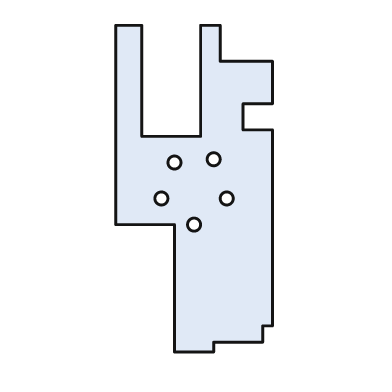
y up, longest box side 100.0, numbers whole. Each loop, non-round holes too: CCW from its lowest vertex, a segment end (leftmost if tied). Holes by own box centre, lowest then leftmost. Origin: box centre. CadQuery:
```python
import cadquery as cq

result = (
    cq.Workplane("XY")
    .moveTo(-6.0, -50.0)
    .lineTo(6.0, -50.0)
    .lineTo(6.0, -47.0)
    .lineTo(21.0, -47.0)
    .lineTo(21.0, -42.0)
    .lineTo(24.0, -42.0)
    .lineTo(24.0, 18.0)
    .lineTo(15.0, 18.0)
    .lineTo(15.0, 26.0)
    .lineTo(24.0, 26.0)
    .lineTo(24.0, 39.0)
    .lineTo(8.0, 39.0)
    .lineTo(8.0, 50.0)
    .lineTo(2.0, 50.0)
    .lineTo(2.0, 16.0)
    .lineTo(-16.0, 16.0)
    .lineTo(-16.0, 50.0)
    .lineTo(-24.0, 50.0)
    .lineTo(-24.0, -11.0)
    .lineTo(-6.0, -11.0)
    .close()
    .moveTo(0.0, -11.0)
    .circle(2.0)
    .moveTo(-10.0, -3.0)
    .circle(2.0)
    .moveTo(10.0, -3.0)
    .circle(2.0)
    .moveTo(-6.0, 8.0)
    .circle(2.0)
    .moveTo(6.0, 9.0)
    .circle(2.0)
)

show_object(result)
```